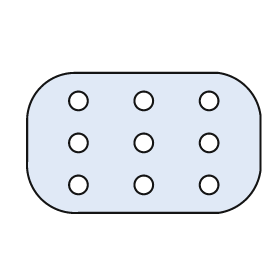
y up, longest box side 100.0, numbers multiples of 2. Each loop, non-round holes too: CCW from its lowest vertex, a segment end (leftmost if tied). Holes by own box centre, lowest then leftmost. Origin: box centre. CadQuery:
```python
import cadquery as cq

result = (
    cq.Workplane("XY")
    .moveTo(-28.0, -30.0)
    .lineTo(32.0, -30.0)
    .threePointArc((44.0, -24.0), (50.0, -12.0))
    .lineTo(50.0, 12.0)
    .threePointArc((44.0, 24.0), (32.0, 30.0))
    .lineTo(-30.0, 30.0)
    .threePointArc((-44.0, 24.0), (-50.0, 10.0))
    .lineTo(-50.0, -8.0)
    .threePointArc((-44.0, -24.0), (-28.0, -30.0))
    .close()
    .moveTo(-28.0, -18.0)
    .circle(4.0)
    .moveTo(0.0, -18.0)
    .circle(4.0)
    .moveTo(28.0, -18.0)
    .circle(4.0)
    .moveTo(-28.0, 0.0)
    .circle(4.0)
    .moveTo(0.0, 0.0)
    .circle(4.0)
    .moveTo(28.0, 0.0)
    .circle(4.0)
    .moveTo(-28.0, 18.0)
    .circle(4.0)
    .moveTo(0.0, 18.0)
    .circle(4.0)
    .moveTo(28.0, 18.0)
    .circle(4.0)
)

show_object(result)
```